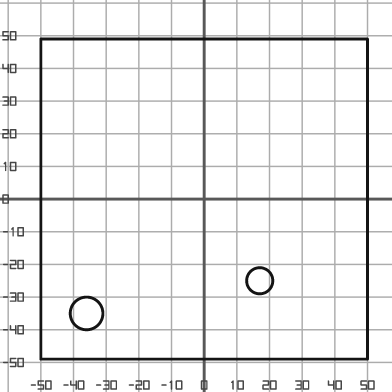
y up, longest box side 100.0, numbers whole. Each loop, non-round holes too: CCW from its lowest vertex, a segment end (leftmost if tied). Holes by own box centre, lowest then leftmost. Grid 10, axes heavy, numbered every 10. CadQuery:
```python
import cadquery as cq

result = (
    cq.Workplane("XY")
    .moveTo(-50.0, -49.0)
    .lineTo(50.0, -49.0)
    .lineTo(50.0, 49.0)
    .lineTo(-50.0, 49.0)
    .close()
    .moveTo(-36.0, -35.0)
    .circle(5.0)
    .moveTo(17.0, -25.0)
    .circle(4.0)
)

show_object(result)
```